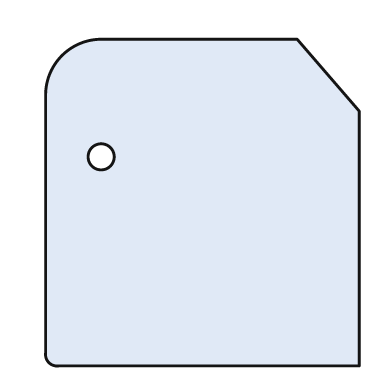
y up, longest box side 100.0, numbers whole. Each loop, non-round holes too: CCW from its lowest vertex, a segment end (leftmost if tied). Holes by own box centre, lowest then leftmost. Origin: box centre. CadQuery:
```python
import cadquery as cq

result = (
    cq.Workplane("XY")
    .moveTo(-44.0, -50.0)
    .lineTo(48.0, -50.0)
    .lineTo(48.0, 28.0)
    .lineTo(29.0, 50.0)
    .lineTo(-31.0, 50.0)
    .threePointArc((-43.0, 45.0), (-48.0, 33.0))
    .lineTo(-48.0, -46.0)
    .threePointArc((-47.0, -49.0), (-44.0, -50.0))
    .close()
    .moveTo(-31.0, 14.0)
    .circle(4.0)
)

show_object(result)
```